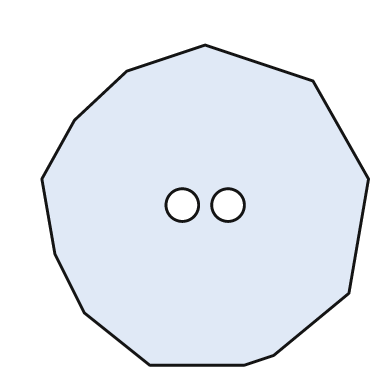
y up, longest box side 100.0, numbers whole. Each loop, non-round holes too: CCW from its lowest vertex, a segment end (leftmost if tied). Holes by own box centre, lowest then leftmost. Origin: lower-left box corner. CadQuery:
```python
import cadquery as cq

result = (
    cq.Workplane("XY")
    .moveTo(33.0, 0.0)
    .lineTo(62.0, 0.0)
    .lineTo(71.0, 3.0)
    .lineTo(94.0, 22.0)
    .lineTo(100.0, 57.0)
    .lineTo(83.0, 87.0)
    .lineTo(50.0, 98.0)
    .lineTo(26.0, 90.0)
    .lineTo(10.0, 75.0)
    .lineTo(0.0, 57.0)
    .lineTo(4.0, 34.0)
    .lineTo(13.0, 16.0)
    .close()
    .moveTo(43.0, 49.0)
    .circle(5.0)
    .moveTo(57.0, 49.0)
    .circle(5.0)
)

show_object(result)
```